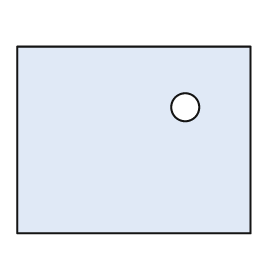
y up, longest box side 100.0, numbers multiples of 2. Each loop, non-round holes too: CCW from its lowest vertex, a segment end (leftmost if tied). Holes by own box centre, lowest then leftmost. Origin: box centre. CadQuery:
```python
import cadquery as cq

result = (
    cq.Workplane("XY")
    .moveTo(-50.0, -40.0)
    .lineTo(50.0, -40.0)
    .lineTo(50.0, 40.0)
    .lineTo(-50.0, 40.0)
    .close()
    .moveTo(22.0, 14.0)
    .circle(6.0)
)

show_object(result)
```